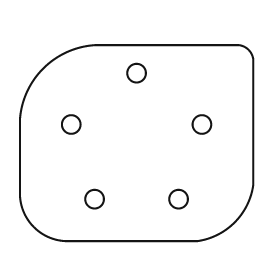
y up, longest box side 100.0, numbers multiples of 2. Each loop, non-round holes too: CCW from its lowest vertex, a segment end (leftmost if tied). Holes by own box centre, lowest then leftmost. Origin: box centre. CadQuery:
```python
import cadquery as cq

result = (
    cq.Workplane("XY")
    .moveTo(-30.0, -42.0)
    .lineTo(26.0, -42.0)
    .threePointArc((42.0, -34.0), (50.0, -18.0))
    .lineTo(50.0, 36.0)
    .threePointArc((48.0, 40.0), (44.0, 42.0))
    .lineTo(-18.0, 42.0)
    .threePointArc((-40.0, 32.0), (-50.0, 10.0))
    .lineTo(-50.0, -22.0)
    .threePointArc((-44.0, -36.0), (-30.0, -42.0))
    .close()
    .moveTo(-18.0, -24.0)
    .circle(4.0)
    .moveTo(18.0, -24.0)
    .circle(4.0)
    .moveTo(-28.0, 8.0)
    .circle(4.0)
    .moveTo(28.0, 8.0)
    .circle(4.0)
    .moveTo(0.0, 30.0)
    .circle(4.0)
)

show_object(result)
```